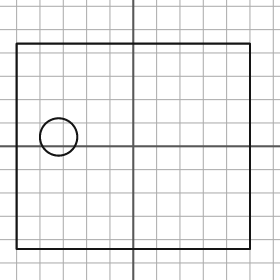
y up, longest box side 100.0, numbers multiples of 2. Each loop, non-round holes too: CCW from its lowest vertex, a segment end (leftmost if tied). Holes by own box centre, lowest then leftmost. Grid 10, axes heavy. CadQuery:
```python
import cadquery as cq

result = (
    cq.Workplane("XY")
    .moveTo(-50.0, -44.0)
    .lineTo(50.0, -44.0)
    .lineTo(50.0, 44.0)
    .lineTo(-50.0, 44.0)
    .close()
    .moveTo(-32.0, 4.0)
    .circle(8.0)
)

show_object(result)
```